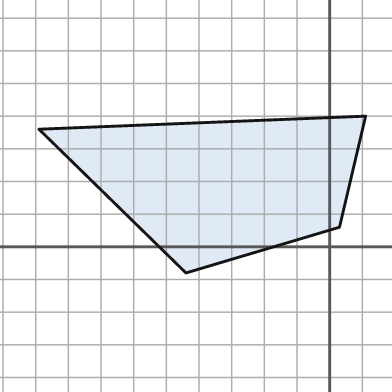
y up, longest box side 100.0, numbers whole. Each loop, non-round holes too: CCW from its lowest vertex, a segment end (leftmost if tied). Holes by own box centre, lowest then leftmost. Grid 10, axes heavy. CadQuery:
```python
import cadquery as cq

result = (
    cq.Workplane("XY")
    .moveTo(-44.0, -8.0)
    .lineTo(3.0, 6.0)
    .lineTo(11.0, 40.0)
    .lineTo(-89.0, 36.0)
    .close()
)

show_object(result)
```